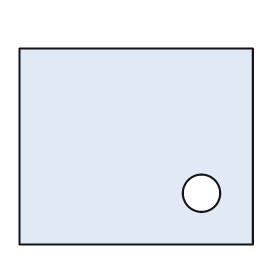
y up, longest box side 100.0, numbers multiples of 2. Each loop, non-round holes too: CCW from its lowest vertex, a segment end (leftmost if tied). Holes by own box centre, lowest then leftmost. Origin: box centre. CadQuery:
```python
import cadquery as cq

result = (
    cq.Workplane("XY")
    .moveTo(-50.0, -42.0)
    .lineTo(50.0, -42.0)
    .lineTo(50.0, 42.0)
    .lineTo(-50.0, 42.0)
    .close()
    .moveTo(28.0, -20.0)
    .circle(8.0)
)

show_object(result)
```